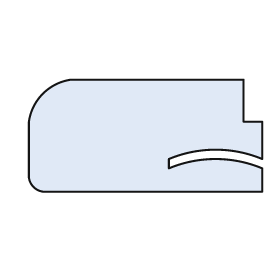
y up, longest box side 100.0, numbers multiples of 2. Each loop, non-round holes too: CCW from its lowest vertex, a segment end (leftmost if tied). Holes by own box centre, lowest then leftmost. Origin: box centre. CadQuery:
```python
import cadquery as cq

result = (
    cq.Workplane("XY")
    .moveTo(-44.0, -24.0)
    .lineTo(50.0, -24.0)
    .lineTo(50.0, -14.0)
    .threePointArc((30.0, -10.0), (10.0, -14.0))
    .lineTo(10.0, -10.0)
    .threePointArc((30.0, -6.0), (50.0, -10.0))
    .lineTo(50.0, 6.0)
    .lineTo(42.0, 6.0)
    .lineTo(42.0, 24.0)
    .lineTo(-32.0, 24.0)
    .threePointArc((-44.0, 18.0), (-50.0, 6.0))
    .lineTo(-50.0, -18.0)
    .threePointArc((-48.0, -22.0), (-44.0, -24.0))
    .close()
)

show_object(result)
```